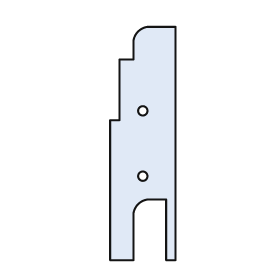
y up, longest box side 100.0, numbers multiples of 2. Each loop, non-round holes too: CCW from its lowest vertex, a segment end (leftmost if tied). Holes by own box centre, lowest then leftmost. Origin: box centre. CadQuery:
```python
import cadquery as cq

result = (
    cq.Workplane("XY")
    .moveTo(-14.0, -50.0)
    .lineTo(-4.0, -50.0)
    .lineTo(-4.0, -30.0)
    .threePointArc((-2.0, -26.0), (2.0, -24.0))
    .lineTo(10.0, -24.0)
    .lineTo(10.0, -50.0)
    .lineTo(14.0, -50.0)
    .lineTo(14.0, 50.0)
    .lineTo(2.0, 50.0)
    .threePointArc((-2.0, 48.0), (-4.0, 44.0))
    .lineTo(-4.0, 36.0)
    .lineTo(-10.0, 36.0)
    .lineTo(-10.0, 10.0)
    .lineTo(-14.0, 10.0)
    .close()
    .moveTo(0.0, -14.0)
    .circle(2.0)
    .moveTo(0.0, 14.0)
    .circle(2.0)
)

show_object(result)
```